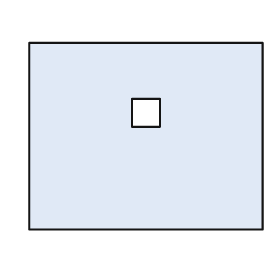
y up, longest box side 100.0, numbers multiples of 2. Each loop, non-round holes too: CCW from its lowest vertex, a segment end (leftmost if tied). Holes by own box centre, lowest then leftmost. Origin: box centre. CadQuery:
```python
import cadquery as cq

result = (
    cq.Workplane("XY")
    .moveTo(-50.0, -40.0)
    .lineTo(50.0, -40.0)
    .lineTo(50.0, 40.0)
    .lineTo(-50.0, 40.0)
    .close()
    .moveTo(-6.0, 4.0)
    .lineTo(6.0, 4.0)
    .lineTo(6.0, 16.0)
    .lineTo(-6.0, 16.0)
    .close()
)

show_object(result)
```